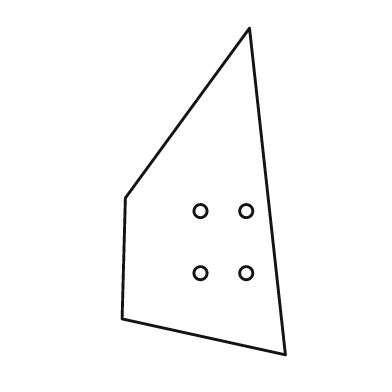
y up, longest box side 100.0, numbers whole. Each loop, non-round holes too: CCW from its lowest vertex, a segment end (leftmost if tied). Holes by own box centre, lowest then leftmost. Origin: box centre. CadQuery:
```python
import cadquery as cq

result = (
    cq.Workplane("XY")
    .moveTo(25.0, -50.0)
    .lineTo(14.0, 50.0)
    .lineTo(-24.0, -2.0)
    .lineTo(-25.0, -39.0)
    .close()
    .moveTo(-1.0, -25.0)
    .circle(2.0)
    .moveTo(13.0, -25.0)
    .circle(2.0)
    .moveTo(-1.0, -6.0)
    .circle(2.0)
    .moveTo(13.0, -6.0)
    .circle(2.0)
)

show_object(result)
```